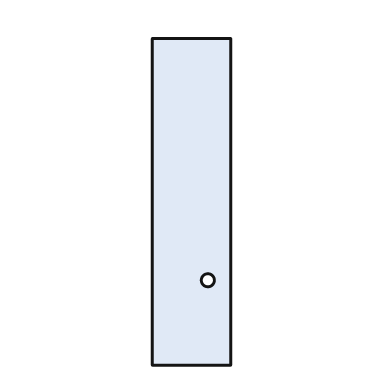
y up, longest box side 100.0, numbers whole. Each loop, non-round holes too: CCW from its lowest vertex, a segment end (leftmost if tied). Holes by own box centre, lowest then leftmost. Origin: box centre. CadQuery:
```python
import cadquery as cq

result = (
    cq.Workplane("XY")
    .moveTo(-12.0, -50.0)
    .lineTo(12.0, -50.0)
    .lineTo(12.0, 50.0)
    .lineTo(-12.0, 50.0)
    .close()
    .moveTo(5.0, -24.0)
    .circle(2.0)
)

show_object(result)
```